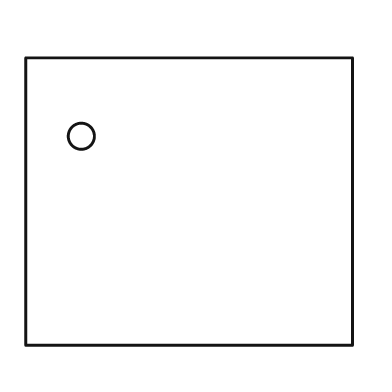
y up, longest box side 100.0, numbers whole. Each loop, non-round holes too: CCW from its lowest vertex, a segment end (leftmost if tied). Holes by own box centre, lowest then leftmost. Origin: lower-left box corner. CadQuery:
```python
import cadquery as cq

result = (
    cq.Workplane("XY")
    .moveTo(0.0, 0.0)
    .lineTo(100.0, 0.0)
    .lineTo(100.0, 88.0)
    .lineTo(0.0, 88.0)
    .close()
    .moveTo(17.0, 64.0)
    .circle(4.0)
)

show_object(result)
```